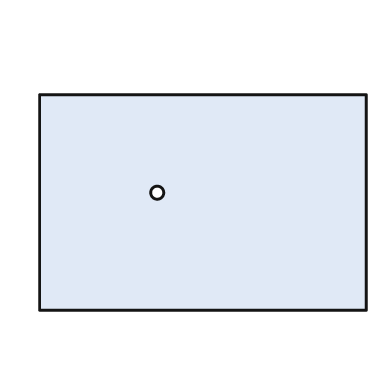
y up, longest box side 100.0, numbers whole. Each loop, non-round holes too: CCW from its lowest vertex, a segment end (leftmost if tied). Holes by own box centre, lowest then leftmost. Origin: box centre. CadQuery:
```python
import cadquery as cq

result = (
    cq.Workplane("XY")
    .moveTo(-50.0, -33.0)
    .lineTo(50.0, -33.0)
    .lineTo(50.0, 33.0)
    .lineTo(-50.0, 33.0)
    .close()
    .moveTo(-14.0, 3.0)
    .circle(2.0)
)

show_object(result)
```